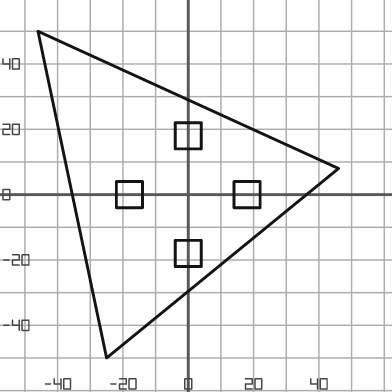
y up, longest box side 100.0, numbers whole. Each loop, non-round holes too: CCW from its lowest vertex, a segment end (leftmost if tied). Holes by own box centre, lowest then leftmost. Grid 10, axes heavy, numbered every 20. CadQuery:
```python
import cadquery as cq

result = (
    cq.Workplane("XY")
    .moveTo(-25.0, -50.0)
    .lineTo(46.0, 8.0)
    .lineTo(-46.0, 50.0)
    .close()
    .moveTo(-4.0, -22.0)
    .lineTo(4.0, -22.0)
    .lineTo(4.0, -14.0)
    .lineTo(-4.0, -14.0)
    .close()
    .moveTo(-22.0, -4.0)
    .lineTo(-14.0, -4.0)
    .lineTo(-14.0, 4.0)
    .lineTo(-22.0, 4.0)
    .close()
    .moveTo(14.0, -4.0)
    .lineTo(22.0, -4.0)
    .lineTo(22.0, 4.0)
    .lineTo(14.0, 4.0)
    .close()
    .moveTo(-4.0, 14.0)
    .lineTo(4.0, 14.0)
    .lineTo(4.0, 22.0)
    .lineTo(-4.0, 22.0)
    .close()
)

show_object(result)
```